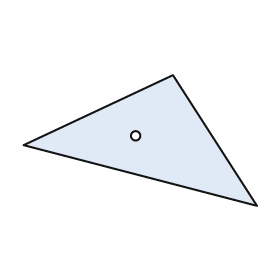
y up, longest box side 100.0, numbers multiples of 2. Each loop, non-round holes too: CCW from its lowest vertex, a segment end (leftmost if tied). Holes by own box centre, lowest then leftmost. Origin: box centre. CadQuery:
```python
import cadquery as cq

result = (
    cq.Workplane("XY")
    .moveTo(50.0, -28.0)
    .lineTo(14.0, 28.0)
    .lineTo(-50.0, -2.0)
    .close()
    .moveTo(-2.0, 2.0)
    .circle(2.0)
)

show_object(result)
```